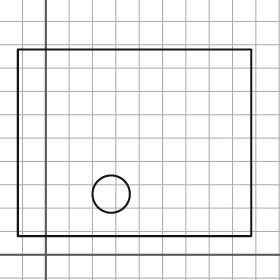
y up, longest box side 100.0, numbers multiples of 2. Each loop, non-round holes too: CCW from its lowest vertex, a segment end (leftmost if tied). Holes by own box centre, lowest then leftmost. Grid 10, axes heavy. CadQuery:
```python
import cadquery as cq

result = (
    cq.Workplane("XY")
    .moveTo(-12.0, 8.0)
    .lineTo(88.0, 8.0)
    .lineTo(88.0, 88.0)
    .lineTo(-12.0, 88.0)
    .close()
    .moveTo(28.0, 26.0)
    .circle(8.0)
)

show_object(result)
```